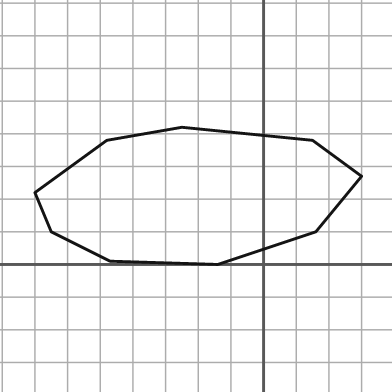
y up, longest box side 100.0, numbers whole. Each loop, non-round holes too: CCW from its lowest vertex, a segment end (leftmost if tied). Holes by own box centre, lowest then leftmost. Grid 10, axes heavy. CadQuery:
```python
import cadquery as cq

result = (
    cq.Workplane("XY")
    .moveTo(-14.0, 0.0)
    .lineTo(16.0, 10.0)
    .lineTo(30.0, 27.0)
    .lineTo(15.0, 38.0)
    .lineTo(-25.0, 42.0)
    .lineTo(-48.0, 38.0)
    .lineTo(-70.0, 22.0)
    .lineTo(-65.0, 10.0)
    .lineTo(-47.0, 1.0)
    .close()
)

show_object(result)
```